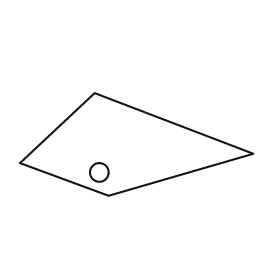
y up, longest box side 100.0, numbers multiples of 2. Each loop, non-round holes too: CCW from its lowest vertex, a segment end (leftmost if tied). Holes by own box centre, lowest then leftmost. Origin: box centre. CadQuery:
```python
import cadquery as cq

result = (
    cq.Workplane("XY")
    .moveTo(-12.0, -22.0)
    .lineTo(50.0, -4.0)
    .lineTo(-18.0, 22.0)
    .lineTo(-50.0, -8.0)
    .close()
    .moveTo(-16.0, -12.0)
    .circle(4.0)
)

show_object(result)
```